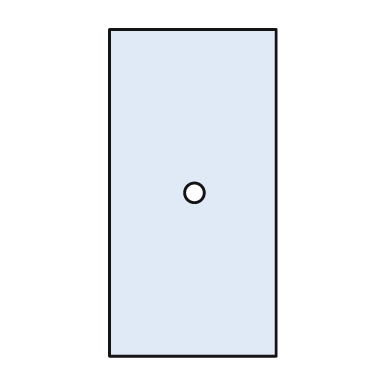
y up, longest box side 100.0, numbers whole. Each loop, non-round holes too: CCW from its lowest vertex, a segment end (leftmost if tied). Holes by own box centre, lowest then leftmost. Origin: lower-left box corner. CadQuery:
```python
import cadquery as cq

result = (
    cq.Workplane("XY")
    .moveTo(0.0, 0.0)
    .lineTo(51.0, 0.0)
    .lineTo(51.0, 100.0)
    .lineTo(0.0, 100.0)
    .close()
    .moveTo(26.0, 50.0)
    .circle(3.0)
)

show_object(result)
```